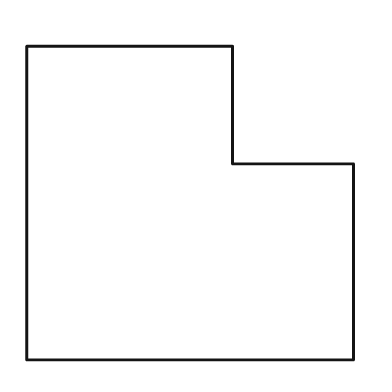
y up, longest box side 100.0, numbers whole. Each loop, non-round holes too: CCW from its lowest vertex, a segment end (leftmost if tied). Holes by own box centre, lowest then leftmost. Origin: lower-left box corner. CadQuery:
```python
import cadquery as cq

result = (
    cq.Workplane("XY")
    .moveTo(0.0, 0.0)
    .lineTo(100.0, 0.0)
    .lineTo(100.0, 60.0)
    .lineTo(63.0, 60.0)
    .lineTo(63.0, 96.0)
    .lineTo(0.0, 96.0)
    .close()
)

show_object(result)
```